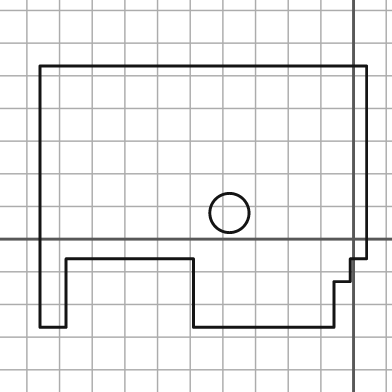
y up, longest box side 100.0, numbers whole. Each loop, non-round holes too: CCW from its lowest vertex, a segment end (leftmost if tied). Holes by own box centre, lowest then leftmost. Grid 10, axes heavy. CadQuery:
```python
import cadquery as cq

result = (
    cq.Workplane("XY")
    .moveTo(-96.0, -27.0)
    .lineTo(-88.0, -27.0)
    .lineTo(-88.0, -6.0)
    .lineTo(-49.0, -6.0)
    .lineTo(-49.0, -27.0)
    .lineTo(-6.0, -27.0)
    .lineTo(-6.0, -13.0)
    .lineTo(-1.0, -13.0)
    .lineTo(-1.0, -6.0)
    .lineTo(4.0, -6.0)
    .lineTo(4.0, 53.0)
    .lineTo(-96.0, 53.0)
    .close()
    .moveTo(-38.0, 8.0)
    .circle(6.0)
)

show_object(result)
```